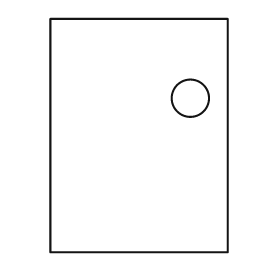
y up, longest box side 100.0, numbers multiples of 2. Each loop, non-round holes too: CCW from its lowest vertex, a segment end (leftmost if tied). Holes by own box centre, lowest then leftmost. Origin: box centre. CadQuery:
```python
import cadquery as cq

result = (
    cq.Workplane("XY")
    .moveTo(-38.0, -50.0)
    .lineTo(38.0, -50.0)
    .lineTo(38.0, 50.0)
    .lineTo(-38.0, 50.0)
    .close()
    .moveTo(22.0, 16.0)
    .circle(8.0)
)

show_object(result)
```